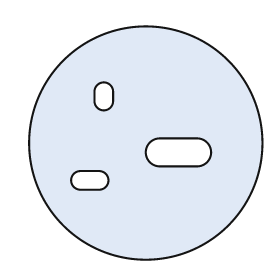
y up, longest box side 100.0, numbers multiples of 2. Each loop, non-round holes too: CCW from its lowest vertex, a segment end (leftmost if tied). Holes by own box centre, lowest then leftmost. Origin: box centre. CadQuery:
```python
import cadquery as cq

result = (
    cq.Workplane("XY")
    .moveTo(0.0, 0.0)
    .circle(50.0)
    .moveTo(-28.0, -20.0)
    .lineTo(-20.0, -20.0)
    .threePointArc((-16.0, -16.0), (-20.0, -12.0))
    .lineTo(-28.0, -12.0)
    .threePointArc((-32.0, -16.0), (-28.0, -20.0))
    .close()
    .moveTo(6.0, -10.0)
    .lineTo(22.0, -10.0)
    .threePointArc((28.0, -4.0), (22.0, 2.0))
    .lineTo(6.0, 2.0)
    .threePointArc((0.0, -4.0), (6.0, -10.0))
    .close()
    .moveTo(-22.0, 18.0)
    .threePointArc((-18.0, 14.0), (-14.0, 18.0))
    .lineTo(-14.0, 22.0)
    .threePointArc((-18.0, 26.0), (-22.0, 22.0))
    .close()
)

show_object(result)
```